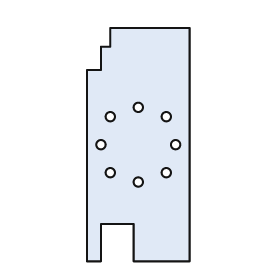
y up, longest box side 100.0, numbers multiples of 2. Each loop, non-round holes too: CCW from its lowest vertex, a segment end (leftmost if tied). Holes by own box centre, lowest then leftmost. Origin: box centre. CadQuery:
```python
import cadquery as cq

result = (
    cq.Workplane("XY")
    .moveTo(-22.0, -50.0)
    .lineTo(-16.0, -50.0)
    .lineTo(-16.0, -34.0)
    .lineTo(-2.0, -34.0)
    .lineTo(-2.0, -50.0)
    .lineTo(22.0, -50.0)
    .lineTo(22.0, 50.0)
    .lineTo(-12.0, 50.0)
    .lineTo(-12.0, 42.0)
    .lineTo(-16.0, 42.0)
    .lineTo(-16.0, 32.0)
    .lineTo(-22.0, 32.0)
    .close()
    .moveTo(0.0, -16.0)
    .circle(2.0)
    .moveTo(-12.0, -12.0)
    .circle(2.0)
    .moveTo(12.0, -12.0)
    .circle(2.0)
    .moveTo(-16.0, 0.0)
    .circle(2.0)
    .moveTo(16.0, 0.0)
    .circle(2.0)
    .moveTo(-12.0, 12.0)
    .circle(2.0)
    .moveTo(12.0, 12.0)
    .circle(2.0)
    .moveTo(0.0, 16.0)
    .circle(2.0)
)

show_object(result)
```